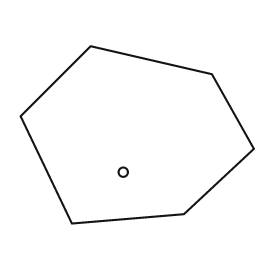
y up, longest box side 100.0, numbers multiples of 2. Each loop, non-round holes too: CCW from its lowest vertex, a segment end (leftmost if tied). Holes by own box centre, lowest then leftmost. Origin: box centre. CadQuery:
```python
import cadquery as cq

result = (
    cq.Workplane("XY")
    .moveTo(-28.0, -38.0)
    .lineTo(20.0, -34.0)
    .lineTo(50.0, -6.0)
    .lineTo(32.0, 26.0)
    .lineTo(-20.0, 38.0)
    .lineTo(-50.0, 8.0)
    .close()
    .moveTo(-6.0, -16.0)
    .circle(2.0)
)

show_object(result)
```